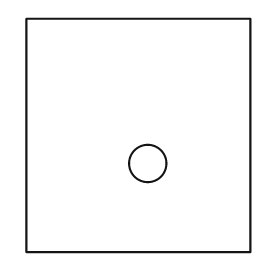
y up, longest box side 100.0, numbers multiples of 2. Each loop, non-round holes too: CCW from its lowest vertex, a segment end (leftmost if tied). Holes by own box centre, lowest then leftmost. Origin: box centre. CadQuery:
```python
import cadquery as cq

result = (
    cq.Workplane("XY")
    .moveTo(-48.0, -50.0)
    .lineTo(48.0, -50.0)
    .lineTo(48.0, 50.0)
    .lineTo(-48.0, 50.0)
    .close()
    .moveTo(4.0, -12.0)
    .circle(8.0)
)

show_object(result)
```